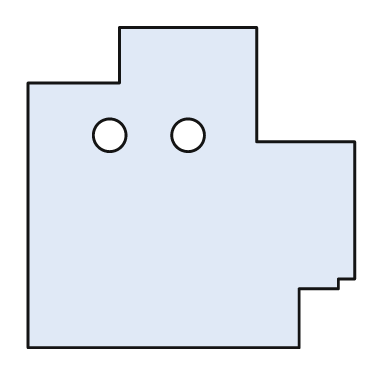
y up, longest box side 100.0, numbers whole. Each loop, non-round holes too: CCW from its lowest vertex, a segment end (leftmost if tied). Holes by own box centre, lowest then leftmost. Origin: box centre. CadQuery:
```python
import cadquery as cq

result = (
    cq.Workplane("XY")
    .moveTo(-50.0, -49.0)
    .lineTo(33.0, -49.0)
    .lineTo(33.0, -31.0)
    .lineTo(45.0, -31.0)
    .lineTo(45.0, -28.0)
    .lineTo(50.0, -28.0)
    .lineTo(50.0, 14.0)
    .lineTo(20.0, 14.0)
    .lineTo(20.0, 49.0)
    .lineTo(-22.0, 49.0)
    .lineTo(-22.0, 32.0)
    .lineTo(-50.0, 32.0)
    .close()
    .moveTo(-25.0, 16.0)
    .circle(5.0)
    .moveTo(-1.0, 16.0)
    .circle(5.0)
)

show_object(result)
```